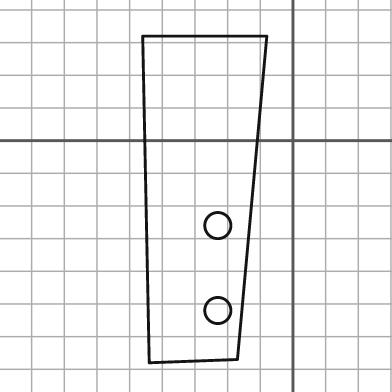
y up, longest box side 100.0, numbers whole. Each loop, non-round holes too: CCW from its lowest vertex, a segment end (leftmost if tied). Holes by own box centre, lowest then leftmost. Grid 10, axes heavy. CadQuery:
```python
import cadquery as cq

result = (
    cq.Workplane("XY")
    .moveTo(-44.0, -68.0)
    .lineTo(-17.0, -67.0)
    .lineTo(-8.0, 32.0)
    .lineTo(-46.0, 32.0)
    .close()
    .moveTo(-23.0, -52.0)
    .circle(4.0)
    .moveTo(-23.0, -26.0)
    .circle(4.0)
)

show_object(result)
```